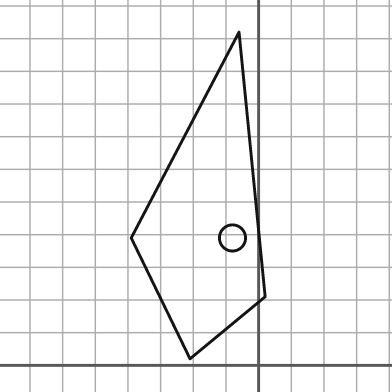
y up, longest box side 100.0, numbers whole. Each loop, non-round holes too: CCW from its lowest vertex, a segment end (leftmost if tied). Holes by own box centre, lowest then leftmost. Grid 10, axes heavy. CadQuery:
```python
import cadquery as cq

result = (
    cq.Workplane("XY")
    .moveTo(-21.0, 2.0)
    .lineTo(2.0, 21.0)
    .lineTo(-6.0, 102.0)
    .lineTo(-39.0, 39.0)
    .close()
    .moveTo(-8.0, 39.0)
    .circle(4.0)
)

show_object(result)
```